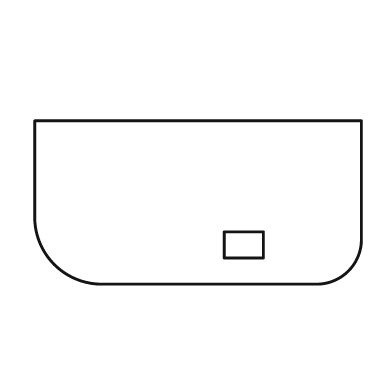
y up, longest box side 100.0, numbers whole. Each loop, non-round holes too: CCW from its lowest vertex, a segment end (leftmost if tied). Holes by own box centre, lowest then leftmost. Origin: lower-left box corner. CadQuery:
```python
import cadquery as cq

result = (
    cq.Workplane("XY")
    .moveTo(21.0, 0.0)
    .lineTo(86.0, 0.0)
    .threePointArc((96.0, 4.0), (100.0, 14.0))
    .lineTo(100.0, 50.0)
    .lineTo(0.0, 50.0)
    .lineTo(0.0, 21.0)
    .threePointArc((6.0, 6.0), (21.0, 0.0))
    .close()
    .moveTo(58.0, 8.0)
    .lineTo(70.0, 8.0)
    .lineTo(70.0, 16.0)
    .lineTo(58.0, 16.0)
    .close()
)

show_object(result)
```